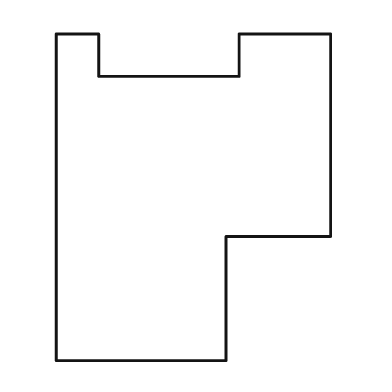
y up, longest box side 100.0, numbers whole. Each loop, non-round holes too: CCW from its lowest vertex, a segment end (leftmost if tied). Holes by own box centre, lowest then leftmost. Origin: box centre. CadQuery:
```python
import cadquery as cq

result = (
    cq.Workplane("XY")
    .moveTo(-42.0, -50.0)
    .lineTo(10.0, -50.0)
    .lineTo(10.0, -12.0)
    .lineTo(42.0, -12.0)
    .lineTo(42.0, 50.0)
    .lineTo(14.0, 50.0)
    .lineTo(14.0, 37.0)
    .lineTo(-29.0, 37.0)
    .lineTo(-29.0, 50.0)
    .lineTo(-42.0, 50.0)
    .close()
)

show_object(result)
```